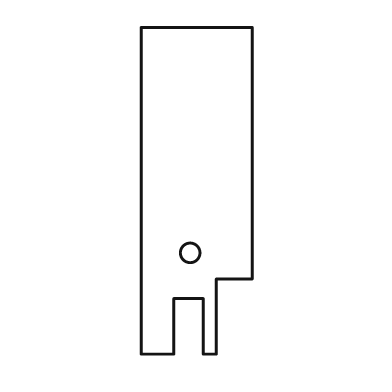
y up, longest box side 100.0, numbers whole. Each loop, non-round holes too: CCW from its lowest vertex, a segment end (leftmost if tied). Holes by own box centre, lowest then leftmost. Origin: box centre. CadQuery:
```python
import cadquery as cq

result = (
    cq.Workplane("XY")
    .moveTo(-17.0, -50.0)
    .lineTo(-7.0, -50.0)
    .lineTo(-7.0, -33.0)
    .lineTo(2.0, -33.0)
    .lineTo(2.0, -50.0)
    .lineTo(6.0, -50.0)
    .lineTo(6.0, -27.0)
    .lineTo(17.0, -27.0)
    .lineTo(17.0, 50.0)
    .lineTo(-17.0, 50.0)
    .close()
    .moveTo(-2.0, -19.0)
    .circle(3.0)
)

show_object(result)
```